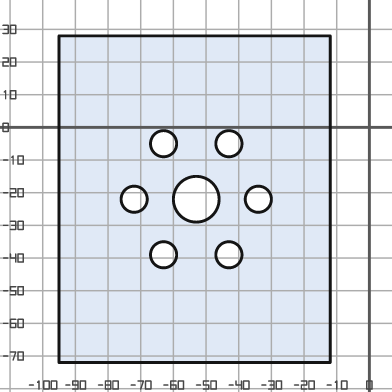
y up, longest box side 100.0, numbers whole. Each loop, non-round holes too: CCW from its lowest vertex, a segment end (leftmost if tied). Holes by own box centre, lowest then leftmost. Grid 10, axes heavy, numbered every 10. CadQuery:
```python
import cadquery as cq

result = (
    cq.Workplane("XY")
    .moveTo(-95.0, -72.0)
    .lineTo(-12.0, -72.0)
    .lineTo(-12.0, 28.0)
    .lineTo(-95.0, 28.0)
    .close()
    .moveTo(-63.0, -39.0)
    .circle(4.0)
    .moveTo(-43.0, -39.0)
    .circle(4.0)
    .moveTo(-72.0, -22.0)
    .circle(4.0)
    .moveTo(-53.0, -22.0)
    .circle(7.0)
    .moveTo(-34.0, -22.0)
    .circle(4.0)
    .moveTo(-63.0, -5.0)
    .circle(4.0)
    .moveTo(-43.0, -5.0)
    .circle(4.0)
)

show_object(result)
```